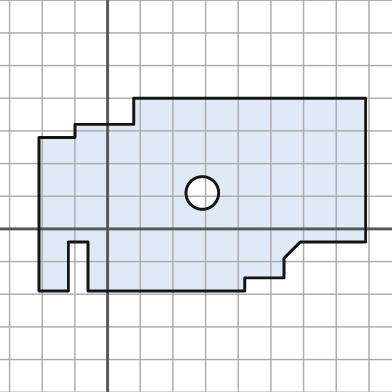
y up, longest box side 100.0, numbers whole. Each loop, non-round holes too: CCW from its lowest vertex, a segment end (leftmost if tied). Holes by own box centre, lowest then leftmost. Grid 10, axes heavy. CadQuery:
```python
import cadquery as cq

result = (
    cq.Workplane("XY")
    .moveTo(-21.0, -19.0)
    .lineTo(-12.0, -19.0)
    .lineTo(-12.0, -4.0)
    .lineTo(-6.0, -4.0)
    .lineTo(-6.0, -19.0)
    .lineTo(42.0, -19.0)
    .lineTo(42.0, -15.0)
    .lineTo(54.0, -15.0)
    .lineTo(54.0, -9.0)
    .lineTo(59.0, -4.0)
    .lineTo(79.0, -4.0)
    .lineTo(79.0, 40.0)
    .lineTo(8.0, 40.0)
    .lineTo(8.0, 32.0)
    .lineTo(-10.0, 32.0)
    .lineTo(-10.0, 28.0)
    .lineTo(-21.0, 28.0)
    .close()
    .moveTo(29.0, 11.0)
    .circle(5.0)
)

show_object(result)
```